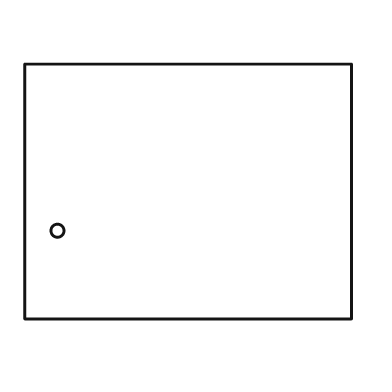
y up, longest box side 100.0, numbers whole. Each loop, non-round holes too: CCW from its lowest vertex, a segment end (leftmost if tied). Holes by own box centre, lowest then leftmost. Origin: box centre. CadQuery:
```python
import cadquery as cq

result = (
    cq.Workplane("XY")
    .moveTo(-50.0, -39.0)
    .lineTo(50.0, -39.0)
    .lineTo(50.0, 39.0)
    .lineTo(-50.0, 39.0)
    .close()
    .moveTo(-40.0, -12.0)
    .circle(2.0)
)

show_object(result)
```